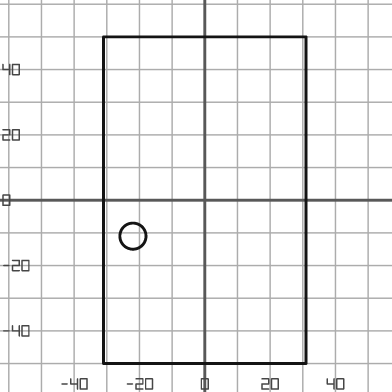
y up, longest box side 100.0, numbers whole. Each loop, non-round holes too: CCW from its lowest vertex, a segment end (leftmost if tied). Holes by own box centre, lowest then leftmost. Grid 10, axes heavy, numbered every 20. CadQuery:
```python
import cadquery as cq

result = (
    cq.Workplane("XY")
    .moveTo(-31.0, -50.0)
    .lineTo(31.0, -50.0)
    .lineTo(31.0, 50.0)
    .lineTo(-31.0, 50.0)
    .close()
    .moveTo(-22.0, -11.0)
    .circle(4.0)
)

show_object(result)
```